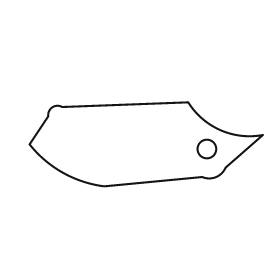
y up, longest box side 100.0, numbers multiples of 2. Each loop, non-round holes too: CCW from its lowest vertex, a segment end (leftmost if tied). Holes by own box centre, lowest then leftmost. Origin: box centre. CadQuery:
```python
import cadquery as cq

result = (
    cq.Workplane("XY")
    .moveTo(-18.0, -18.0)
    .lineTo(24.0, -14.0)
    .threePointArc((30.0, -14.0), (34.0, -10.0))
    .lineTo(50.0, 4.0)
    .threePointArc((32.0, 6.0), (18.0, 18.0))
    .lineTo(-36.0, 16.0)
    .threePointArc((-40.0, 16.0), (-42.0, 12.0))
    .lineTo(-50.0, 0.0)
    .threePointArc((-36.0, -12.0), (-18.0, -18.0))
    .close()
    .moveTo(26.0, -2.0)
    .circle(4.0)
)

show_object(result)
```